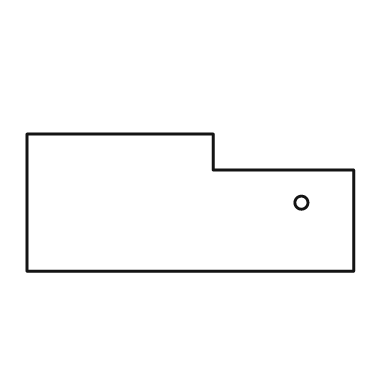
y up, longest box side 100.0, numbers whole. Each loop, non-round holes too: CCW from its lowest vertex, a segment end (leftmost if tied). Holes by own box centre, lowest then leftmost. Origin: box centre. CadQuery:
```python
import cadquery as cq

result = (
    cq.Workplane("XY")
    .moveTo(-50.0, -21.0)
    .lineTo(50.0, -21.0)
    .lineTo(50.0, 10.0)
    .lineTo(7.0, 10.0)
    .lineTo(7.0, 21.0)
    .lineTo(-50.0, 21.0)
    .close()
    .moveTo(34.0, 0.0)
    .circle(2.0)
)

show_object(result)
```